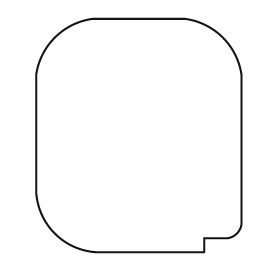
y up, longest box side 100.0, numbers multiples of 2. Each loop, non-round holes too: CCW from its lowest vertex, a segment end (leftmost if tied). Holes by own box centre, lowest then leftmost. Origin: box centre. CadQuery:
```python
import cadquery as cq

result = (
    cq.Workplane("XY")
    .moveTo(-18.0, -50.0)
    .lineTo(28.0, -50.0)
    .lineTo(28.0, -44.0)
    .lineTo(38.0, -44.0)
    .threePointArc((42.0, -42.0), (44.0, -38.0))
    .lineTo(44.0, 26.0)
    .threePointArc((36.0, 42.0), (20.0, 50.0))
    .lineTo(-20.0, 50.0)
    .threePointArc((-36.0, 42.0), (-44.0, 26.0))
    .lineTo(-44.0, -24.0)
    .threePointArc((-36.0, -42.0), (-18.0, -50.0))
    .close()
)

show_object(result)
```